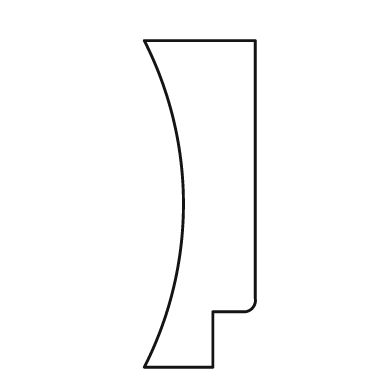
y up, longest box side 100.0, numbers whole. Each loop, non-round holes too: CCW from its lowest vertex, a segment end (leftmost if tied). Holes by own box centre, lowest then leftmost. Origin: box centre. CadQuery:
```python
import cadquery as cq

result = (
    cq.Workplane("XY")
    .moveTo(-17.0, -50.0)
    .lineTo(4.0, -50.0)
    .lineTo(4.0, -33.0)
    .lineTo(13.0, -33.0)
    .threePointArc((16.0, -32.0), (17.0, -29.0))
    .lineTo(17.0, 50.0)
    .lineTo(-17.0, 50.0)
    .threePointArc((-5.0, 0.0), (-17.0, -50.0))
    .close()
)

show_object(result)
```